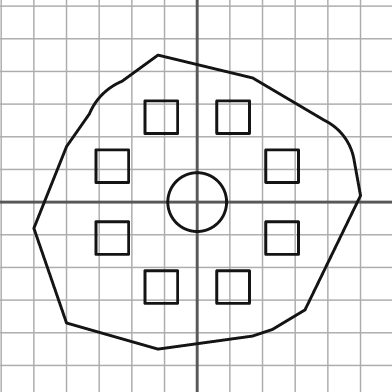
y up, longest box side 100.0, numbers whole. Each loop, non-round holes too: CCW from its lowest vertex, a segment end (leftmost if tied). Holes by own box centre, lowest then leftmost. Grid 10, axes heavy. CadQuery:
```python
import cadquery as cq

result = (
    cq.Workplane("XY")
    .moveTo(-12.0, -45.0)
    .lineTo(17.0, -41.0)
    .lineTo(23.0, -39.0)
    .lineTo(33.0, -33.0)
    .lineTo(50.0, 2.0)
    .lineTo(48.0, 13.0)
    .threePointArc((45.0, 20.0), (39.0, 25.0))
    .lineTo(17.0, 38.0)
    .lineTo(-12.0, 45.0)
    .lineTo(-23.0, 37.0)
    .threePointArc((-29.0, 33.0), (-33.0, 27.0))
    .lineTo(-40.0, 17.0)
    .lineTo(-50.0, -8.0)
    .lineTo(-40.0, -37.0)
    .close()
    .moveTo(-16.0, -31.0)
    .lineTo(-6.0, -31.0)
    .lineTo(-6.0, -21.0)
    .lineTo(-16.0, -21.0)
    .close()
    .moveTo(6.0, -31.0)
    .lineTo(16.0, -31.0)
    .lineTo(16.0, -21.0)
    .lineTo(6.0, -21.0)
    .close()
    .moveTo(-31.0, -16.0)
    .lineTo(-21.0, -16.0)
    .lineTo(-21.0, -6.0)
    .lineTo(-31.0, -6.0)
    .close()
    .moveTo(21.0, -16.0)
    .lineTo(31.0, -16.0)
    .lineTo(31.0, -6.0)
    .lineTo(21.0, -6.0)
    .close()
    .moveTo(0.0, 0.0)
    .circle(9.0)
    .moveTo(-31.0, 6.0)
    .lineTo(-21.0, 6.0)
    .lineTo(-21.0, 16.0)
    .lineTo(-31.0, 16.0)
    .close()
    .moveTo(21.0, 6.0)
    .lineTo(31.0, 6.0)
    .lineTo(31.0, 16.0)
    .lineTo(21.0, 16.0)
    .close()
    .moveTo(-16.0, 21.0)
    .lineTo(-6.0, 21.0)
    .lineTo(-6.0, 31.0)
    .lineTo(-16.0, 31.0)
    .close()
    .moveTo(6.0, 21.0)
    .lineTo(16.0, 21.0)
    .lineTo(16.0, 31.0)
    .lineTo(6.0, 31.0)
    .close()
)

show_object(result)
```